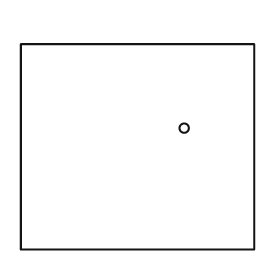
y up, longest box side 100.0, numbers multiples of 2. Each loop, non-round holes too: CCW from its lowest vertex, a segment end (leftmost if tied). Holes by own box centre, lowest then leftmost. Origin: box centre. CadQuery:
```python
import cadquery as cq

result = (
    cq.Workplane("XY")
    .moveTo(-50.0, -44.0)
    .lineTo(50.0, -44.0)
    .lineTo(50.0, 44.0)
    .lineTo(-50.0, 44.0)
    .close()
    .moveTo(20.0, 8.0)
    .circle(2.0)
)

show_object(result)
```